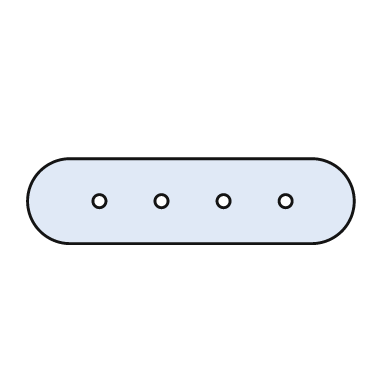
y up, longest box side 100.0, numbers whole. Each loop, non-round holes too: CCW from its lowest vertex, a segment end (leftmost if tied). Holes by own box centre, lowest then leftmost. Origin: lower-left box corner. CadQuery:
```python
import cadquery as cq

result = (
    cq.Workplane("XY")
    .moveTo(13.0, 0.0)
    .lineTo(87.0, 0.0)
    .threePointArc((100.0, 13.0), (87.0, 26.0))
    .lineTo(13.0, 26.0)
    .threePointArc((0.0, 13.0), (13.0, 0.0))
    .close()
    .moveTo(22.0, 13.0)
    .circle(2.0)
    .moveTo(41.0, 13.0)
    .circle(2.0)
    .moveTo(60.0, 13.0)
    .circle(2.0)
    .moveTo(79.0, 13.0)
    .circle(2.0)
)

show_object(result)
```